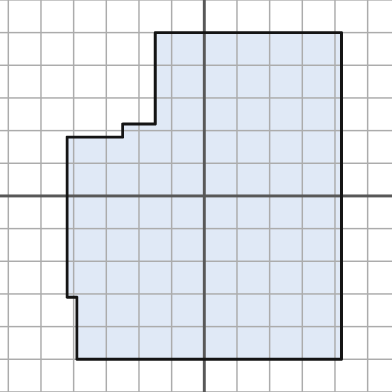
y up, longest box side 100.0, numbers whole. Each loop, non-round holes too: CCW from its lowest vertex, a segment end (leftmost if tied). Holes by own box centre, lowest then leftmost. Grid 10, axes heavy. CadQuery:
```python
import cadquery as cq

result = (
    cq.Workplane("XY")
    .moveTo(-39.0, -50.0)
    .lineTo(42.0, -50.0)
    .lineTo(42.0, 50.0)
    .lineTo(-15.0, 50.0)
    .lineTo(-15.0, 22.0)
    .lineTo(-25.0, 22.0)
    .lineTo(-25.0, 18.0)
    .lineTo(-42.0, 18.0)
    .lineTo(-42.0, -31.0)
    .lineTo(-39.0, -31.0)
    .close()
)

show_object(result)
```